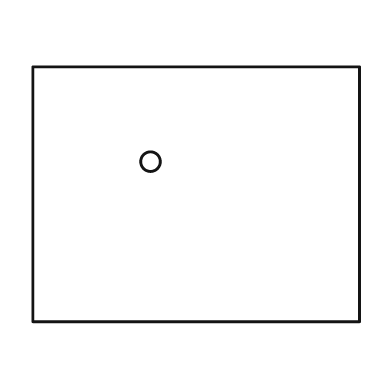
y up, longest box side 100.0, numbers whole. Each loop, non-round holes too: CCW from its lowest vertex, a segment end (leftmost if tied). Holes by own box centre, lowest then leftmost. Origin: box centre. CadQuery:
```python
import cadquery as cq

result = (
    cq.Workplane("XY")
    .moveTo(-50.0, -39.0)
    .lineTo(50.0, -39.0)
    .lineTo(50.0, 39.0)
    .lineTo(-50.0, 39.0)
    .close()
    .moveTo(-14.0, 10.0)
    .circle(3.0)
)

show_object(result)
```